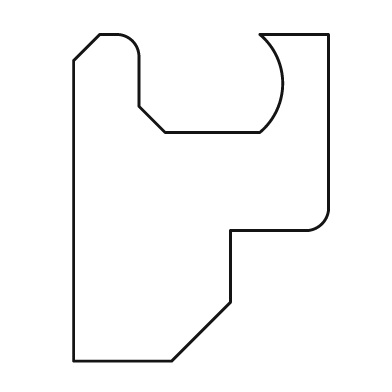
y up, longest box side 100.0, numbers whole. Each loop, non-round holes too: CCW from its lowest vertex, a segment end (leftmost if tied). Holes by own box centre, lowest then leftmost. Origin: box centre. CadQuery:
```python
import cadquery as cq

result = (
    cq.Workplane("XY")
    .moveTo(-39.0, -50.0)
    .lineTo(-9.0, -50.0)
    .lineTo(9.0, -32.0)
    .lineTo(9.0, -10.0)
    .lineTo(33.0, -10.0)
    .threePointArc((37.0, -8.0), (39.0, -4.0))
    .lineTo(39.0, 50.0)
    .lineTo(18.0, 50.0)
    .threePointArc((25.0, 35.0), (18.0, 20.0))
    .lineTo(-11.0, 20.0)
    .lineTo(-19.0, 28.0)
    .lineTo(-19.0, 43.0)
    .threePointArc((-21.0, 48.0), (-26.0, 50.0))
    .lineTo(-31.0, 50.0)
    .lineTo(-39.0, 42.0)
    .close()
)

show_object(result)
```